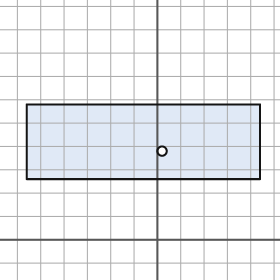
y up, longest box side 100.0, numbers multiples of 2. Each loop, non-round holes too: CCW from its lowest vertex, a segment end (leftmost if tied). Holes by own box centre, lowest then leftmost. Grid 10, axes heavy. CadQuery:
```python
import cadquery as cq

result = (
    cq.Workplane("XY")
    .moveTo(-56.0, 26.0)
    .lineTo(44.0, 26.0)
    .lineTo(44.0, 58.0)
    .lineTo(-56.0, 58.0)
    .close()
    .moveTo(2.0, 38.0)
    .circle(2.0)
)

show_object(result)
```